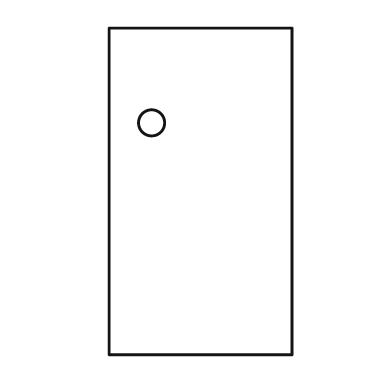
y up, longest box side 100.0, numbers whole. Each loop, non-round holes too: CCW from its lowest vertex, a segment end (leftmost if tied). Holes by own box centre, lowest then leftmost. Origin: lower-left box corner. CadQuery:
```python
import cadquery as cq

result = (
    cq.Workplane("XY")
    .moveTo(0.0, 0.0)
    .lineTo(56.0, 0.0)
    .lineTo(56.0, 100.0)
    .lineTo(0.0, 100.0)
    .close()
    .moveTo(13.0, 71.0)
    .circle(4.0)
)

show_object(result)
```